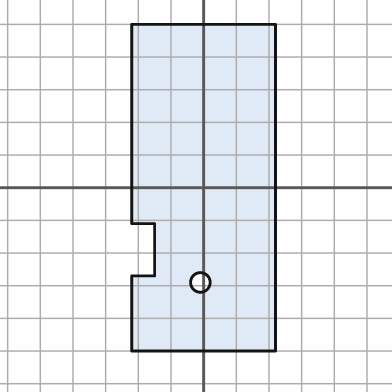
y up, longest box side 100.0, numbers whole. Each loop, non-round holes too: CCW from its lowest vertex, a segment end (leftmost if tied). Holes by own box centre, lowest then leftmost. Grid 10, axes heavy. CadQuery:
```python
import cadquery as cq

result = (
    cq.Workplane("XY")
    .moveTo(-22.0, -50.0)
    .lineTo(22.0, -50.0)
    .lineTo(22.0, 50.0)
    .lineTo(-22.0, 50.0)
    .lineTo(-22.0, -11.0)
    .lineTo(-15.0, -11.0)
    .lineTo(-15.0, -27.0)
    .lineTo(-22.0, -27.0)
    .close()
    .moveTo(-1.0, -29.0)
    .circle(3.0)
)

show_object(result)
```